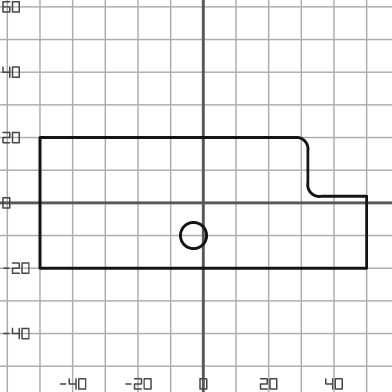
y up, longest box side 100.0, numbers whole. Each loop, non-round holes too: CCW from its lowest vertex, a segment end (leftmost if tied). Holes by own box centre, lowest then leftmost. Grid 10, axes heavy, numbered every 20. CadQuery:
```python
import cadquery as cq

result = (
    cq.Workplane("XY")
    .moveTo(-50.0, -20.0)
    .lineTo(50.0, -20.0)
    .lineTo(50.0, 2.0)
    .lineTo(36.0, 2.0)
    .threePointArc((33.0, 3.0), (32.0, 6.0))
    .lineTo(32.0, 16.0)
    .threePointArc((31.0, 19.0), (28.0, 20.0))
    .lineTo(-50.0, 20.0)
    .close()
    .moveTo(-3.0, -10.0)
    .circle(4.0)
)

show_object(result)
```